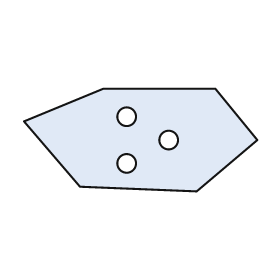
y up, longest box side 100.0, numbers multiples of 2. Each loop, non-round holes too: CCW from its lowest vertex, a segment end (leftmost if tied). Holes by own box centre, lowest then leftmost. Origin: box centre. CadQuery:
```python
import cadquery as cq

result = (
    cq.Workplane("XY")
    .moveTo(24.0, -22.0)
    .lineTo(50.0, 0.0)
    .lineTo(32.0, 22.0)
    .lineTo(-16.0, 22.0)
    .lineTo(-50.0, 8.0)
    .lineTo(-26.0, -20.0)
    .close()
    .moveTo(-6.0, -10.0)
    .circle(4.0)
    .moveTo(12.0, 0.0)
    .circle(4.0)
    .moveTo(-6.0, 10.0)
    .circle(4.0)
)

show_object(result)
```